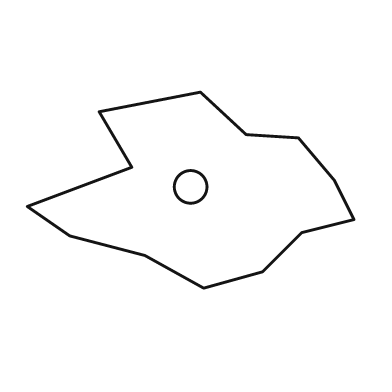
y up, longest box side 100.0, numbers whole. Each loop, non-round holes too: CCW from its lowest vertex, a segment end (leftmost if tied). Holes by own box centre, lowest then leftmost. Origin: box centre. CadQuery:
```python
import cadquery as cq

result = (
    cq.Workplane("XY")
    .moveTo(4.0, -30.0)
    .lineTo(22.0, -25.0)
    .lineTo(34.0, -13.0)
    .lineTo(50.0, -9.0)
    .lineTo(44.0, 3.0)
    .lineTo(33.0, 16.0)
    .lineTo(17.0, 17.0)
    .lineTo(3.0, 30.0)
    .lineTo(-28.0, 24.0)
    .lineTo(-18.0, 7.0)
    .lineTo(-50.0, -5.0)
    .lineTo(-37.0, -14.0)
    .lineTo(-14.0, -20.0)
    .close()
    .moveTo(0.0, 1.0)
    .circle(5.0)
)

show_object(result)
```